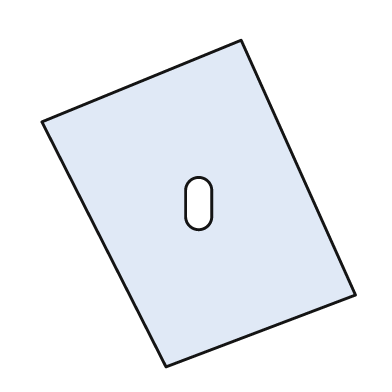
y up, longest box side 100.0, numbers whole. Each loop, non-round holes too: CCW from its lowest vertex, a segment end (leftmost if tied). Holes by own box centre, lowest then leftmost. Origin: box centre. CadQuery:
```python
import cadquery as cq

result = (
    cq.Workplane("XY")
    .moveTo(-10.0, -50.0)
    .lineTo(48.0, -28.0)
    .lineTo(13.0, 50.0)
    .lineTo(-48.0, 25.0)
    .close()
    .moveTo(-4.0, -4.0)
    .threePointArc((0.0, -8.0), (4.0, -4.0))
    .lineTo(4.0, 4.0)
    .threePointArc((0.0, 8.0), (-4.0, 4.0))
    .close()
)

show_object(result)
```